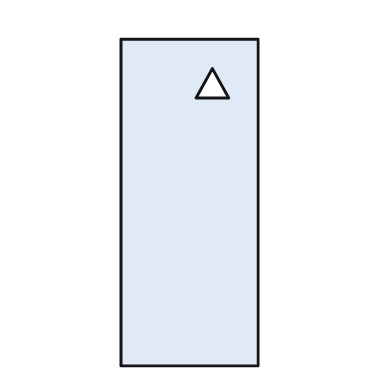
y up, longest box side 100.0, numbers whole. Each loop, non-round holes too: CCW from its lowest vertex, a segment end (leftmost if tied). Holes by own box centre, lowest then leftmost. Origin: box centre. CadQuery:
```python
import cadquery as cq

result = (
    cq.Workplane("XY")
    .moveTo(-21.0, -50.0)
    .lineTo(21.0, -50.0)
    .lineTo(21.0, 50.0)
    .lineTo(-21.0, 50.0)
    .close()
    .moveTo(2.0, 32.0)
    .lineTo(12.0, 32.0)
    .lineTo(7.0, 41.0)
    .close()
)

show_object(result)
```